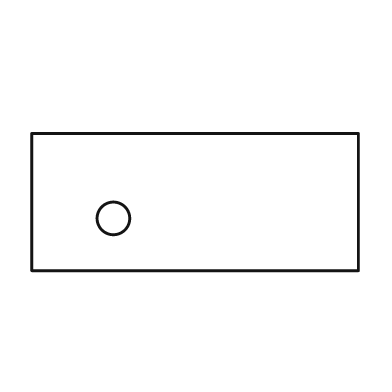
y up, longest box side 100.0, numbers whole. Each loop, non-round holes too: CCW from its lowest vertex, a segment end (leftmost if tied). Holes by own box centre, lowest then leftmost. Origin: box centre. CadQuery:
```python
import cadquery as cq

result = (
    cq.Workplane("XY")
    .moveTo(-50.0, -21.0)
    .lineTo(50.0, -21.0)
    .lineTo(50.0, 21.0)
    .lineTo(-50.0, 21.0)
    .close()
    .moveTo(-25.0, -5.0)
    .circle(5.0)
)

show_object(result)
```